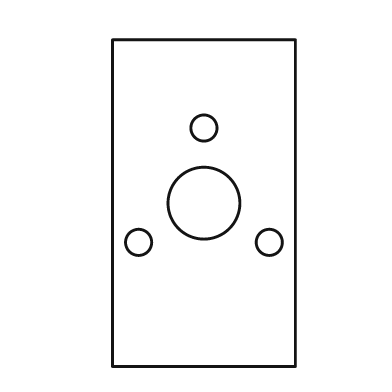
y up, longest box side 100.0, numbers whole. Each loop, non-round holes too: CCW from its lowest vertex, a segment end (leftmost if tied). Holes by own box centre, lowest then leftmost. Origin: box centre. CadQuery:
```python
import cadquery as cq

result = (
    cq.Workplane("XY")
    .moveTo(-28.0, -50.0)
    .lineTo(28.0, -50.0)
    .lineTo(28.0, 50.0)
    .lineTo(-28.0, 50.0)
    .close()
    .moveTo(-20.0, -12.0)
    .circle(4.0)
    .moveTo(20.0, -12.0)
    .circle(4.0)
    .moveTo(0.0, 0.0)
    .circle(11.0)
    .moveTo(0.0, 23.0)
    .circle(4.0)
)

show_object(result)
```